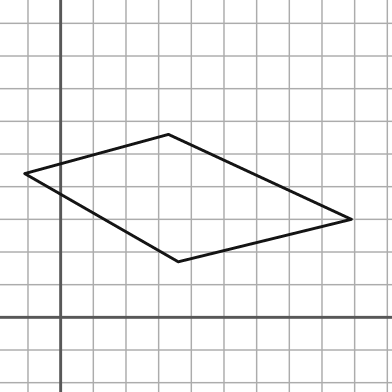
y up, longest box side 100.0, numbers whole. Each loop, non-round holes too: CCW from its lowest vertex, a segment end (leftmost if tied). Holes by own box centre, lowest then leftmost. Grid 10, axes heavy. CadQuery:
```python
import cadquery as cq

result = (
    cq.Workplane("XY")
    .moveTo(36.0, 17.0)
    .lineTo(89.0, 30.0)
    .lineTo(33.0, 56.0)
    .lineTo(-11.0, 44.0)
    .close()
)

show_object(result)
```